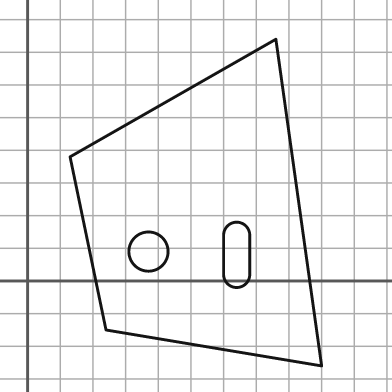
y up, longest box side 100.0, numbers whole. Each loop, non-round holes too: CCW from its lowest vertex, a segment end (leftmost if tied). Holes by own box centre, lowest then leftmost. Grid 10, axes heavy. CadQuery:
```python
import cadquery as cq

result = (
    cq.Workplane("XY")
    .moveTo(90.0, -26.0)
    .lineTo(76.0, 74.0)
    .lineTo(13.0, 38.0)
    .lineTo(24.0, -15.0)
    .close()
    .moveTo(60.0, 2.0)
    .threePointArc((64.0, -2.0), (68.0, 2.0))
    .lineTo(68.0, 14.0)
    .threePointArc((64.0, 18.0), (60.0, 14.0))
    .close()
    .moveTo(37.0, 9.0)
    .circle(6.0)
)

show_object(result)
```